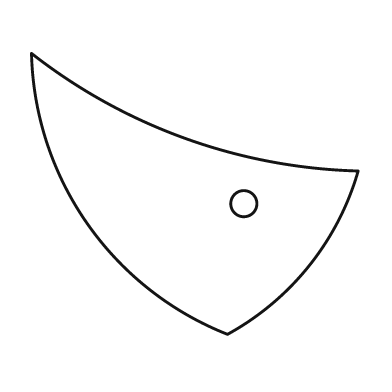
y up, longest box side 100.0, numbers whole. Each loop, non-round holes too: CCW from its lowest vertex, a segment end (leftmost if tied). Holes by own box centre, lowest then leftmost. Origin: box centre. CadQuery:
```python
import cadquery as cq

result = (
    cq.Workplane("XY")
    .moveTo(10.0, -43.0)
    .threePointArc((35.0, -22.0), (50.0, 7.0))
    .threePointArc((-3.0, 17.0), (-50.0, 43.0))
    .threePointArc((-33.0, -9.0), (10.0, -43.0))
    .close()
    .moveTo(15.0, -3.0)
    .circle(4.0)
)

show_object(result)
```